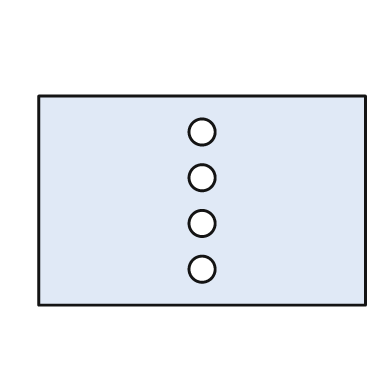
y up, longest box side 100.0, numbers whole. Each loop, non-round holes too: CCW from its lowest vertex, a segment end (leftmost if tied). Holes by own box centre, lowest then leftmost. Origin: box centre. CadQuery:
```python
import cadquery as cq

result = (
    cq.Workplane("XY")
    .moveTo(-50.0, -32.0)
    .lineTo(50.0, -32.0)
    .lineTo(50.0, 32.0)
    .lineTo(-50.0, 32.0)
    .close()
    .moveTo(0.0, -21.0)
    .circle(4.0)
    .moveTo(0.0, -7.0)
    .circle(4.0)
    .moveTo(0.0, 7.0)
    .circle(4.0)
    .moveTo(0.0, 21.0)
    .circle(4.0)
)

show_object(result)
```